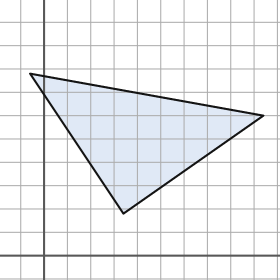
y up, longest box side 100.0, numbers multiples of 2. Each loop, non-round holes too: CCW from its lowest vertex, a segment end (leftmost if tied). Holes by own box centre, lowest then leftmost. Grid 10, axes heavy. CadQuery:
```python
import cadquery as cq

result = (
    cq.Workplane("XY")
    .moveTo(34.0, 18.0)
    .lineTo(94.0, 60.0)
    .lineTo(-6.0, 78.0)
    .close()
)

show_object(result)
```